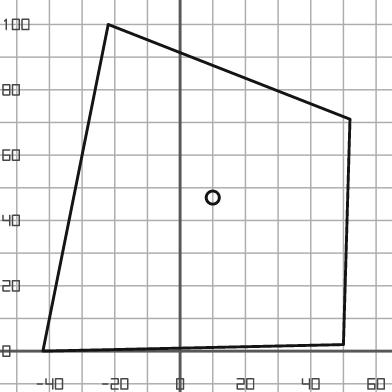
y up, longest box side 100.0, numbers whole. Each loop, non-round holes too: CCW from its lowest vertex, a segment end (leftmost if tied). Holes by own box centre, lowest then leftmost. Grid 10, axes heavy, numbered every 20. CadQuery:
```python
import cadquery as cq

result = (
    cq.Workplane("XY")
    .moveTo(-42.0, 0.0)
    .lineTo(50.0, 2.0)
    .lineTo(52.0, 71.0)
    .lineTo(-22.0, 100.0)
    .close()
    .moveTo(10.0, 47.0)
    .circle(2.0)
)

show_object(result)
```